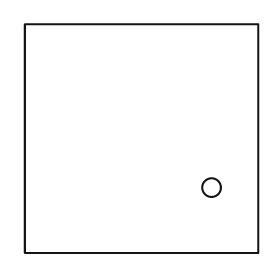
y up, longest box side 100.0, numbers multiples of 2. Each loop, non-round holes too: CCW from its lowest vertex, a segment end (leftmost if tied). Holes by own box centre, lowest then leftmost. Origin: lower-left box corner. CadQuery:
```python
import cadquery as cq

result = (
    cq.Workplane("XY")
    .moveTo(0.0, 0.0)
    .lineTo(100.0, 0.0)
    .lineTo(100.0, 98.0)
    .lineTo(0.0, 98.0)
    .close()
    .moveTo(80.0, 28.0)
    .circle(4.0)
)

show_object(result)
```